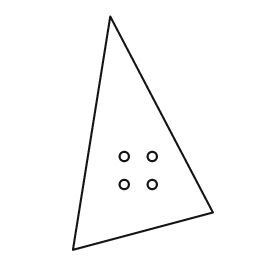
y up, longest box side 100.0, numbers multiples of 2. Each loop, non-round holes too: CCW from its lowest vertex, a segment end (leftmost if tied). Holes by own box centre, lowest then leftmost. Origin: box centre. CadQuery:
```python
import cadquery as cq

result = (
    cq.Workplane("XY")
    .moveTo(-30.0, -50.0)
    .lineTo(30.0, -34.0)
    .lineTo(-14.0, 50.0)
    .close()
    .moveTo(-8.0, -22.0)
    .circle(2.0)
    .moveTo(4.0, -22.0)
    .circle(2.0)
    .moveTo(-8.0, -10.0)
    .circle(2.0)
    .moveTo(4.0, -10.0)
    .circle(2.0)
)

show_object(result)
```